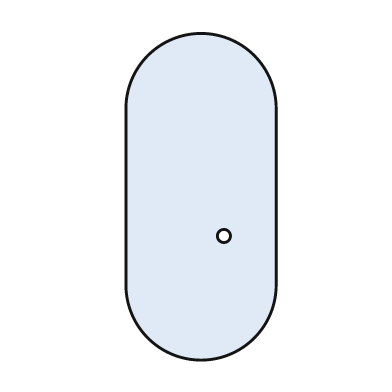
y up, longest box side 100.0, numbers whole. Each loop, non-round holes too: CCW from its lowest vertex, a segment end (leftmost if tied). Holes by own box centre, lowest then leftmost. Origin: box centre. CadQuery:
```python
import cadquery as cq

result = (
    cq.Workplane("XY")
    .moveTo(-23.0, -27.0)
    .threePointArc((0.0, -50.0), (23.0, -27.0))
    .lineTo(23.0, 27.0)
    .threePointArc((0.0, 50.0), (-23.0, 27.0))
    .close()
    .moveTo(7.0, -12.0)
    .circle(2.0)
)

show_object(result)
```